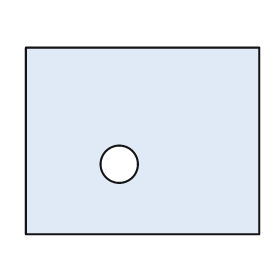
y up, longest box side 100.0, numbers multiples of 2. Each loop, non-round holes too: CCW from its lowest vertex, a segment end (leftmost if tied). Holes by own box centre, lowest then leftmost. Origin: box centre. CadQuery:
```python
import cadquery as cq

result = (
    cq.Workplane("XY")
    .moveTo(-50.0, -40.0)
    .lineTo(50.0, -40.0)
    .lineTo(50.0, 40.0)
    .lineTo(-50.0, 40.0)
    .close()
    .moveTo(-10.0, -10.0)
    .circle(8.0)
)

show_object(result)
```